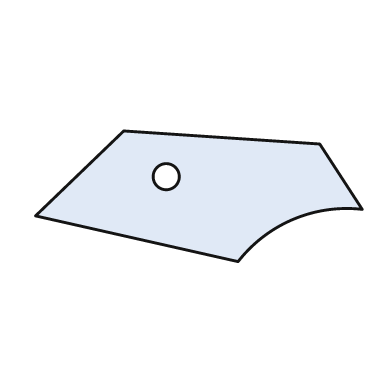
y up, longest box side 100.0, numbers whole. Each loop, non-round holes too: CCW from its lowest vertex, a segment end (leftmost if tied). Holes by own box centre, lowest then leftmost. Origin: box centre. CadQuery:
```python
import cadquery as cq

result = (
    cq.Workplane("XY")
    .moveTo(12.0, -20.0)
    .threePointArc((29.0, -7.0), (50.0, -4.0))
    .lineTo(37.0, 16.0)
    .lineTo(-23.0, 20.0)
    .lineTo(-50.0, -6.0)
    .close()
    .moveTo(-10.0, 6.0)
    .circle(4.0)
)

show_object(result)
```